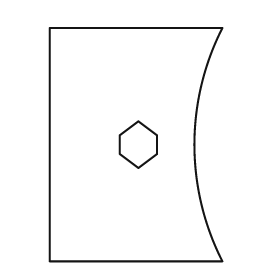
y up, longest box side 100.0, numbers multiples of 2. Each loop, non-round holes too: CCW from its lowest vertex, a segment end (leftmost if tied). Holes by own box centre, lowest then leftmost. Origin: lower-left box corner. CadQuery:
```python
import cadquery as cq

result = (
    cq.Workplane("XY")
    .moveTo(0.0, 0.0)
    .lineTo(74.0, 0.0)
    .threePointArc((62.0, 50.0), (74.0, 100.0))
    .lineTo(0.0, 100.0)
    .close()
    .moveTo(38.0, 40.0)
    .lineTo(46.0, 46.0)
    .lineTo(46.0, 54.0)
    .lineTo(38.0, 60.0)
    .lineTo(30.0, 54.0)
    .lineTo(30.0, 46.0)
    .close()
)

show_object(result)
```